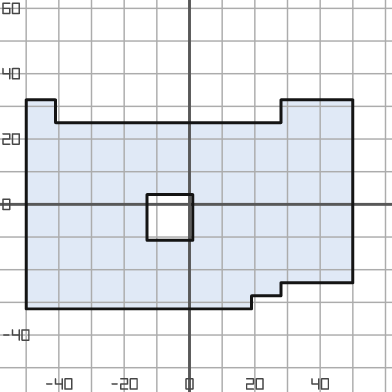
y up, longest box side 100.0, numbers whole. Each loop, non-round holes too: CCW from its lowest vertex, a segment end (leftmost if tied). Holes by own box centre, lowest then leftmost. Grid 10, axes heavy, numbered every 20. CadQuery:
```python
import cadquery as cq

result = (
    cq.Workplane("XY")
    .moveTo(-50.0, -32.0)
    .lineTo(19.0, -32.0)
    .lineTo(19.0, -28.0)
    .lineTo(28.0, -28.0)
    .lineTo(28.0, -24.0)
    .lineTo(50.0, -24.0)
    .lineTo(50.0, 32.0)
    .lineTo(28.0, 32.0)
    .lineTo(28.0, 25.0)
    .lineTo(-41.0, 25.0)
    .lineTo(-41.0, 32.0)
    .lineTo(-50.0, 32.0)
    .close()
    .moveTo(-13.0, -11.0)
    .lineTo(1.0, -11.0)
    .lineTo(1.0, 3.0)
    .lineTo(-13.0, 3.0)
    .close()
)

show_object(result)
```